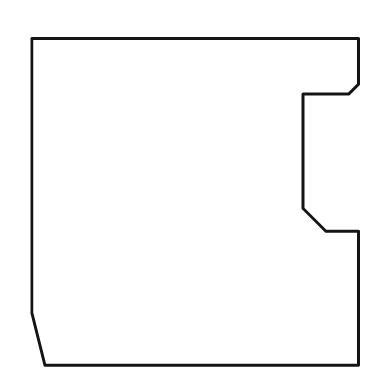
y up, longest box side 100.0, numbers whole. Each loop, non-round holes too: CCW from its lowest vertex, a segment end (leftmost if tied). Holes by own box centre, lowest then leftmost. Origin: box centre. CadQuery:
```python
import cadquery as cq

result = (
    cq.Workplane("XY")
    .moveTo(-46.0, -50.0)
    .lineTo(50.0, -50.0)
    .lineTo(50.0, -9.0)
    .lineTo(40.0, -9.0)
    .lineTo(33.0, -2.0)
    .lineTo(33.0, 33.0)
    .lineTo(47.0, 33.0)
    .lineTo(50.0, 36.0)
    .lineTo(50.0, 50.0)
    .lineTo(-50.0, 50.0)
    .lineTo(-50.0, -34.0)
    .close()
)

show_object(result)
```